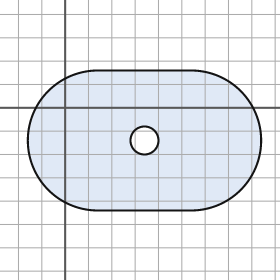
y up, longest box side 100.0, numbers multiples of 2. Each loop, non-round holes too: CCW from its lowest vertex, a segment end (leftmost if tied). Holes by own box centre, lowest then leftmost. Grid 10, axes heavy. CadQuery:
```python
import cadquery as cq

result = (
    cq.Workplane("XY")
    .moveTo(14.0, -44.0)
    .lineTo(54.0, -44.0)
    .threePointArc((84.0, -14.0), (54.0, 16.0))
    .lineTo(14.0, 16.0)
    .threePointArc((-16.0, -14.0), (14.0, -44.0))
    .close()
    .moveTo(34.0, -14.0)
    .circle(6.0)
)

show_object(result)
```